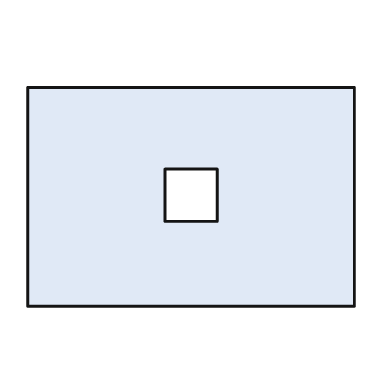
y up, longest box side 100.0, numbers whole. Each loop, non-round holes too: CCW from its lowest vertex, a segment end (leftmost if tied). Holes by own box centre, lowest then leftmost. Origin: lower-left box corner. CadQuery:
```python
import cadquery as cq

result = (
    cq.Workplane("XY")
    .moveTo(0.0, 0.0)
    .lineTo(100.0, 0.0)
    .lineTo(100.0, 67.0)
    .lineTo(0.0, 67.0)
    .close()
    .moveTo(42.0, 26.0)
    .lineTo(58.0, 26.0)
    .lineTo(58.0, 42.0)
    .lineTo(42.0, 42.0)
    .close()
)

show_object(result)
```